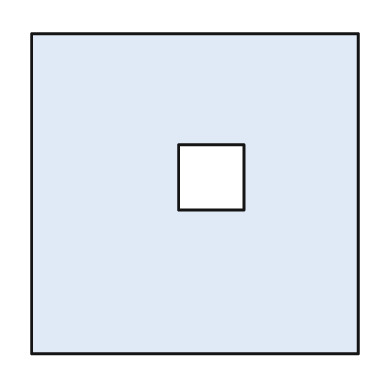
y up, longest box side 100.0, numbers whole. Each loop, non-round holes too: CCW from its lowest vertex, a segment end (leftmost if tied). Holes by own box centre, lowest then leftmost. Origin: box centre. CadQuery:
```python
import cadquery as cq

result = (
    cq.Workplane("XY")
    .moveTo(-50.0, -49.0)
    .lineTo(50.0, -49.0)
    .lineTo(50.0, 49.0)
    .lineTo(-50.0, 49.0)
    .close()
    .moveTo(-5.0, -5.0)
    .lineTo(15.0, -5.0)
    .lineTo(15.0, 15.0)
    .lineTo(-5.0, 15.0)
    .close()
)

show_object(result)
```